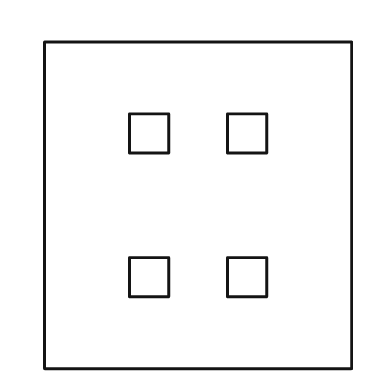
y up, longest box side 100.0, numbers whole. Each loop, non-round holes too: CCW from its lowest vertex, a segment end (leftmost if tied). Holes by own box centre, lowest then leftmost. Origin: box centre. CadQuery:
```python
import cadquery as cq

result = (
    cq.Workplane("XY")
    .moveTo(-47.0, -50.0)
    .lineTo(47.0, -50.0)
    .lineTo(47.0, 50.0)
    .lineTo(-47.0, 50.0)
    .close()
    .moveTo(-21.0, -28.0)
    .lineTo(-9.0, -28.0)
    .lineTo(-9.0, -16.0)
    .lineTo(-21.0, -16.0)
    .close()
    .moveTo(9.0, -28.0)
    .lineTo(21.0, -28.0)
    .lineTo(21.0, -16.0)
    .lineTo(9.0, -16.0)
    .close()
    .moveTo(-21.0, 16.0)
    .lineTo(-9.0, 16.0)
    .lineTo(-9.0, 28.0)
    .lineTo(-21.0, 28.0)
    .close()
    .moveTo(9.0, 16.0)
    .lineTo(21.0, 16.0)
    .lineTo(21.0, 28.0)
    .lineTo(9.0, 28.0)
    .close()
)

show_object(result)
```